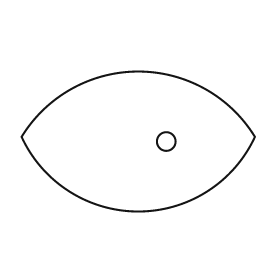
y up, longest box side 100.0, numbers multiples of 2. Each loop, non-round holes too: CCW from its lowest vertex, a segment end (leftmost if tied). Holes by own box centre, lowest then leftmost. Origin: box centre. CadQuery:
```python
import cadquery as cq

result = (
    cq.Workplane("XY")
    .moveTo(-50.0, 2.0)
    .threePointArc((0.0, -30.0), (50.0, 2.0))
    .threePointArc((0.0, 30.0), (-50.0, 2.0))
    .close()
    .moveTo(12.0, 0.0)
    .circle(4.0)
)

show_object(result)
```